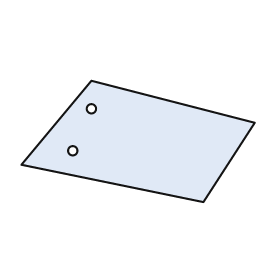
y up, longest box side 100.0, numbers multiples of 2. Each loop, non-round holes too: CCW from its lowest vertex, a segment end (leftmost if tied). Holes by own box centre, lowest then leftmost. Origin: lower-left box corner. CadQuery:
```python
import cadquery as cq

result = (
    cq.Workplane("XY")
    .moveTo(78.0, 0.0)
    .lineTo(100.0, 34.0)
    .lineTo(30.0, 52.0)
    .lineTo(0.0, 16.0)
    .close()
    .moveTo(22.0, 22.0)
    .circle(2.0)
    .moveTo(30.0, 40.0)
    .circle(2.0)
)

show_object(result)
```